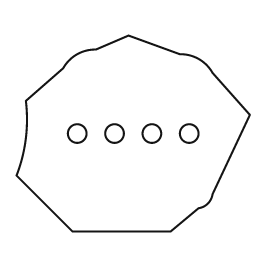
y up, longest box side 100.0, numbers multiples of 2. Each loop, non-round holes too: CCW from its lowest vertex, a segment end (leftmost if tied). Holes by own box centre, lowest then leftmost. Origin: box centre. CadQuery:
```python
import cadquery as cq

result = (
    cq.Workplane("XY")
    .moveTo(-26.0, -42.0)
    .lineTo(16.0, -42.0)
    .lineTo(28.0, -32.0)
    .threePointArc((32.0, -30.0), (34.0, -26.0))
    .lineTo(50.0, 8.0)
    .lineTo(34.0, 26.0)
    .threePointArc((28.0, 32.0), (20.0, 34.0))
    .lineTo(-2.0, 42.0)
    .lineTo(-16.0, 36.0)
    .threePointArc((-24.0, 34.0), (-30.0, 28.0))
    .lineTo(-46.0, 14.0)
    .threePointArc((-46.0, -2.0), (-50.0, -18.0))
    .close()
    .moveTo(-24.0, 0.0)
    .circle(4.0)
    .moveTo(-8.0, 0.0)
    .circle(4.0)
    .moveTo(8.0, 0.0)
    .circle(4.0)
    .moveTo(24.0, 0.0)
    .circle(4.0)
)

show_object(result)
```